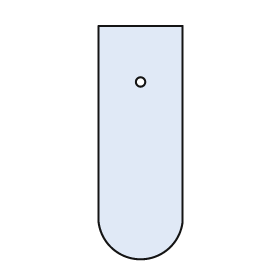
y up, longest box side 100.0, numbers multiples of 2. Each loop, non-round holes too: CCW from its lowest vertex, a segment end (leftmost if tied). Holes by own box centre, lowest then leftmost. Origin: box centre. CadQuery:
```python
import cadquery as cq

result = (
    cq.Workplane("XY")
    .moveTo(-18.0, -34.0)
    .threePointArc((0.0, -50.0), (18.0, -34.0))
    .lineTo(18.0, 50.0)
    .lineTo(-18.0, 50.0)
    .close()
    .moveTo(0.0, 26.0)
    .circle(2.0)
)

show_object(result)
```